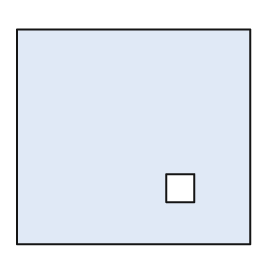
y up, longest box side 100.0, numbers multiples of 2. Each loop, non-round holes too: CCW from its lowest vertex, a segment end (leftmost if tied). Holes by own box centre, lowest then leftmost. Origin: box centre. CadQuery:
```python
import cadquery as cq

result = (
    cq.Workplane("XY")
    .moveTo(-50.0, -46.0)
    .lineTo(50.0, -46.0)
    .lineTo(50.0, 46.0)
    .lineTo(-50.0, 46.0)
    .close()
    .moveTo(14.0, -28.0)
    .lineTo(26.0, -28.0)
    .lineTo(26.0, -16.0)
    .lineTo(14.0, -16.0)
    .close()
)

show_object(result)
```